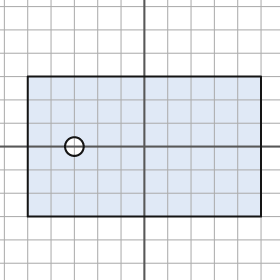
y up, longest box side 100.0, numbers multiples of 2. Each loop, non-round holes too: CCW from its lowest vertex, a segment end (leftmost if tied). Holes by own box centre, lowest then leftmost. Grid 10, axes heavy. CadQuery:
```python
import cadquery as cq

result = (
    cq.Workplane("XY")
    .moveTo(-50.0, -30.0)
    .lineTo(50.0, -30.0)
    .lineTo(50.0, 30.0)
    .lineTo(-50.0, 30.0)
    .close()
    .moveTo(-30.0, 0.0)
    .circle(4.0)
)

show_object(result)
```